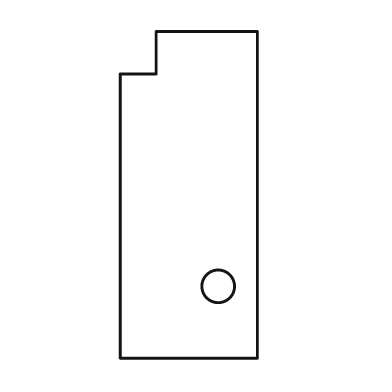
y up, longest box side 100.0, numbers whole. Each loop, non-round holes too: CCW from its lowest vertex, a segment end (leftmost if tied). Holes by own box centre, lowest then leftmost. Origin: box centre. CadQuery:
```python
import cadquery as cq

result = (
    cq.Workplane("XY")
    .moveTo(-21.0, -50.0)
    .lineTo(21.0, -50.0)
    .lineTo(21.0, 50.0)
    .lineTo(-10.0, 50.0)
    .lineTo(-10.0, 37.0)
    .lineTo(-21.0, 37.0)
    .close()
    .moveTo(9.0, -28.0)
    .circle(5.0)
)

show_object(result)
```